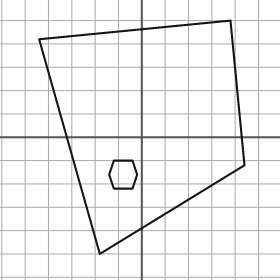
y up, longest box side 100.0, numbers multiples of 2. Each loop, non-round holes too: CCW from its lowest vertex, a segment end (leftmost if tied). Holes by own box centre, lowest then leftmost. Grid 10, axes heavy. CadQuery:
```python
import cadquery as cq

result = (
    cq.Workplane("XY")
    .moveTo(-18.0, -50.0)
    .lineTo(44.0, -12.0)
    .lineTo(38.0, 50.0)
    .lineTo(-44.0, 42.0)
    .close()
    .moveTo(-12.0, -22.0)
    .lineTo(-4.0, -22.0)
    .lineTo(-2.0, -16.0)
    .lineTo(-4.0, -10.0)
    .lineTo(-12.0, -10.0)
    .lineTo(-14.0, -16.0)
    .close()
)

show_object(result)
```